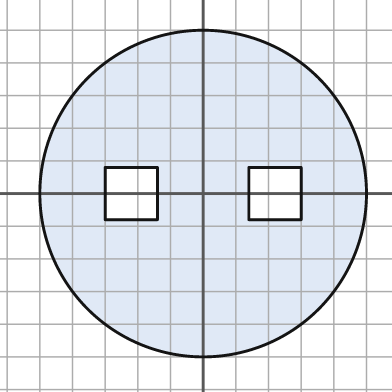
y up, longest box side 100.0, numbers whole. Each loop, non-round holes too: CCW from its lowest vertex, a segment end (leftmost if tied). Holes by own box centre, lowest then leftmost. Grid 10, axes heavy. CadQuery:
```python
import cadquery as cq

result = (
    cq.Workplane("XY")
    .moveTo(0.0, 0.0)
    .circle(50.0)
    .moveTo(-30.0, -8.0)
    .lineTo(-14.0, -8.0)
    .lineTo(-14.0, 8.0)
    .lineTo(-30.0, 8.0)
    .close()
    .moveTo(14.0, -8.0)
    .lineTo(30.0, -8.0)
    .lineTo(30.0, 8.0)
    .lineTo(14.0, 8.0)
    .close()
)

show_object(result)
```